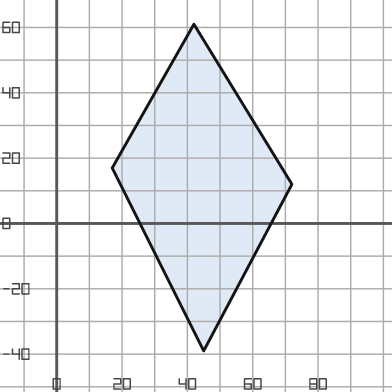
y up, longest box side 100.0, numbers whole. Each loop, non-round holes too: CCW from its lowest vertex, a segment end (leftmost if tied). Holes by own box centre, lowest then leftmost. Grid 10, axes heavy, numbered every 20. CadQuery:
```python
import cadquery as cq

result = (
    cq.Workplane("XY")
    .moveTo(45.0, -39.0)
    .lineTo(72.0, 12.0)
    .lineTo(42.0, 61.0)
    .lineTo(17.0, 17.0)
    .close()
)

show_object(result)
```